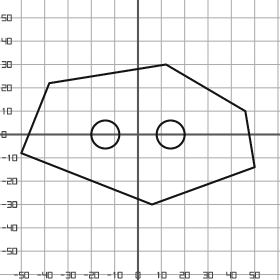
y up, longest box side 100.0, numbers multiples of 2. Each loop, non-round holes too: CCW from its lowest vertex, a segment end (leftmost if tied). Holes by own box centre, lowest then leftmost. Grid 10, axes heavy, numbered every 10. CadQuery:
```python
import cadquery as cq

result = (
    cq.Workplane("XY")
    .moveTo(6.0, -30.0)
    .lineTo(50.0, -14.0)
    .lineTo(46.0, 10.0)
    .lineTo(12.0, 30.0)
    .lineTo(-38.0, 22.0)
    .lineTo(-50.0, -8.0)
    .close()
    .moveTo(-14.0, 0.0)
    .circle(6.0)
    .moveTo(14.0, 0.0)
    .circle(6.0)
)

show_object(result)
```